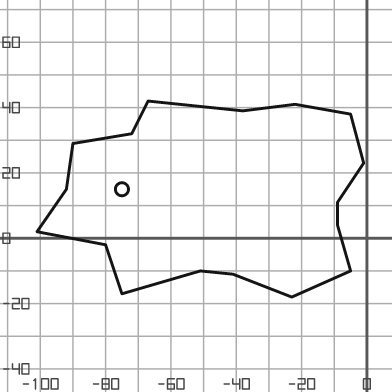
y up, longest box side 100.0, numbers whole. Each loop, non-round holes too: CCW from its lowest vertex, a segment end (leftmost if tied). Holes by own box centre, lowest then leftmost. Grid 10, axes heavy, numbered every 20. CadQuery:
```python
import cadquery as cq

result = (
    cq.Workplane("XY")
    .moveTo(-23.0, -18.0)
    .lineTo(-5.0, -10.0)
    .lineTo(-9.0, 4.0)
    .lineTo(-9.0, 11.0)
    .lineTo(-1.0, 23.0)
    .lineTo(-5.0, 38.0)
    .lineTo(-22.0, 41.0)
    .lineTo(-38.0, 39.0)
    .lineTo(-67.0, 42.0)
    .lineTo(-72.0, 32.0)
    .lineTo(-90.0, 29.0)
    .lineTo(-92.0, 15.0)
    .lineTo(-101.0, 2.0)
    .lineTo(-80.0, -2.0)
    .lineTo(-75.0, -17.0)
    .lineTo(-51.0, -10.0)
    .lineTo(-41.0, -11.0)
    .close()
    .moveTo(-75.0, 15.0)
    .circle(2.0)
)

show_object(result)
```